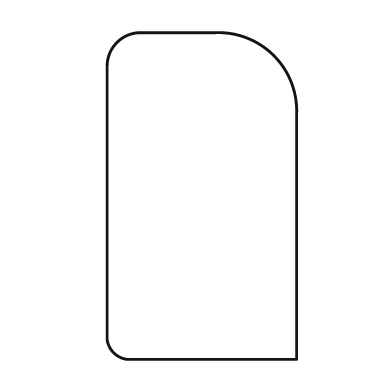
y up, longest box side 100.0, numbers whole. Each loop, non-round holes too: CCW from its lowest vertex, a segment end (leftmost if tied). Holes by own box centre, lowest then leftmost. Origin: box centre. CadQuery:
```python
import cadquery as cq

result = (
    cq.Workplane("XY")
    .moveTo(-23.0, -50.0)
    .lineTo(29.0, -50.0)
    .lineTo(29.0, 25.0)
    .threePointArc((22.0, 43.0), (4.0, 50.0))
    .lineTo(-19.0, 50.0)
    .threePointArc((-26.0, 47.0), (-29.0, 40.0))
    .lineTo(-29.0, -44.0)
    .threePointArc((-27.0, -48.0), (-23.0, -50.0))
    .close()
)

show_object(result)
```